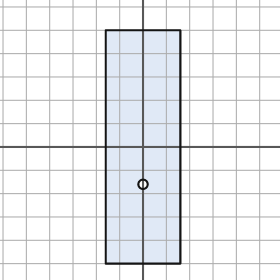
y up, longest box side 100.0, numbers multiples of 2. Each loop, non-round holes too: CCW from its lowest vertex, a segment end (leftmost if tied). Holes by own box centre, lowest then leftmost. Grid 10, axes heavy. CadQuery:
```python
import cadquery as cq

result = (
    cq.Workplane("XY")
    .moveTo(-16.0, -50.0)
    .lineTo(16.0, -50.0)
    .lineTo(16.0, 50.0)
    .lineTo(-16.0, 50.0)
    .close()
    .moveTo(0.0, -16.0)
    .circle(2.0)
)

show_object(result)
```